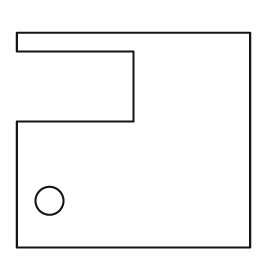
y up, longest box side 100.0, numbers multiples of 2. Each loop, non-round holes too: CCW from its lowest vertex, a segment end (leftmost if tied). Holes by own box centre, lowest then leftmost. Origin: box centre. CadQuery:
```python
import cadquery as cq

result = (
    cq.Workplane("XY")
    .moveTo(-50.0, -46.0)
    .lineTo(50.0, -46.0)
    .lineTo(50.0, 46.0)
    .lineTo(-50.0, 46.0)
    .lineTo(-50.0, 38.0)
    .lineTo(0.0, 38.0)
    .lineTo(0.0, 8.0)
    .lineTo(-50.0, 8.0)
    .close()
    .moveTo(-36.0, -26.0)
    .circle(6.0)
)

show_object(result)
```